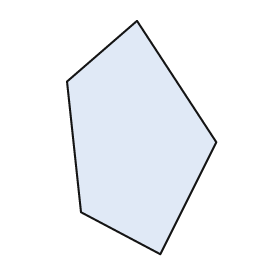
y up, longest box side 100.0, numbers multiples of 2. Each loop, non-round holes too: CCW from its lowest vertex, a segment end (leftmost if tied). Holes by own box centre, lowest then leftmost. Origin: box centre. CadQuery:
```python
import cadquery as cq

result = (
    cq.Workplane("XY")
    .moveTo(8.0, -50.0)
    .lineTo(32.0, -2.0)
    .lineTo(-2.0, 50.0)
    .lineTo(-32.0, 24.0)
    .lineTo(-26.0, -32.0)
    .close()
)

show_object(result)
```